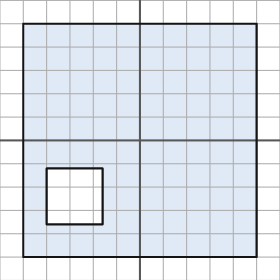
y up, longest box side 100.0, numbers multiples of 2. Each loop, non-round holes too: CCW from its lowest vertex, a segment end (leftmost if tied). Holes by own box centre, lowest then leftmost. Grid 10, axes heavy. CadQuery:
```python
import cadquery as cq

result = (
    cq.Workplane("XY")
    .moveTo(-50.0, -50.0)
    .lineTo(50.0, -50.0)
    .lineTo(50.0, 50.0)
    .lineTo(-50.0, 50.0)
    .close()
    .moveTo(-40.0, -36.0)
    .lineTo(-16.0, -36.0)
    .lineTo(-16.0, -12.0)
    .lineTo(-40.0, -12.0)
    .close()
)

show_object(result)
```